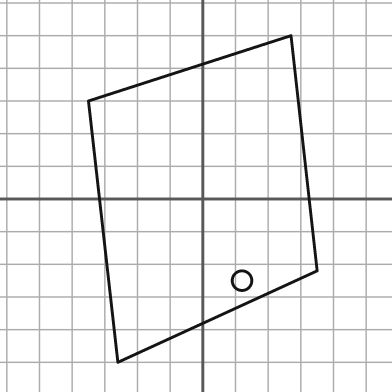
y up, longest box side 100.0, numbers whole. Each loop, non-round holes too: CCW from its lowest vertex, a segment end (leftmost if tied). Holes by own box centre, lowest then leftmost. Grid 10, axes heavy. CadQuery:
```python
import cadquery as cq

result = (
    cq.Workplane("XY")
    .moveTo(-26.0, -50.0)
    .lineTo(35.0, -22.0)
    .lineTo(27.0, 50.0)
    .lineTo(-35.0, 30.0)
    .close()
    .moveTo(12.0, -25.0)
    .circle(3.0)
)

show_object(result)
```